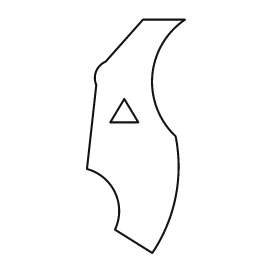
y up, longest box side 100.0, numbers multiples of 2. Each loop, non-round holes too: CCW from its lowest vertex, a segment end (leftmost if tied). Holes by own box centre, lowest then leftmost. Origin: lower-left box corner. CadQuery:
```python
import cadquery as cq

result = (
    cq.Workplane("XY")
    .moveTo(28.0, 0.0)
    .threePointArc((38.0, 24.0), (38.0, 50.0))
    .threePointArc((28.0, 76.0), (42.0, 100.0))
    .lineTo(24.0, 100.0)
    .lineTo(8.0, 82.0)
    .threePointArc((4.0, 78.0), (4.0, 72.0))
    .lineTo(0.0, 36.0)
    .threePointArc((12.0, 26.0), (12.0, 10.0))
    .close()
    .moveTo(10.0, 56.0)
    .lineTo(22.0, 56.0)
    .lineTo(16.0, 66.0)
    .close()
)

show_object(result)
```